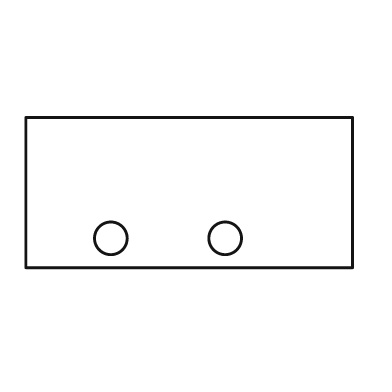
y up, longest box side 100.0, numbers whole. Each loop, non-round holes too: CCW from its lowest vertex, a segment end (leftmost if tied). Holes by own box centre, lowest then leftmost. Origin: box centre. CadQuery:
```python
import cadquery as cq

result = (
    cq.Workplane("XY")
    .moveTo(-50.0, -23.0)
    .lineTo(50.0, -23.0)
    .lineTo(50.0, 23.0)
    .lineTo(-50.0, 23.0)
    .close()
    .moveTo(-24.0, -14.0)
    .circle(5.0)
    .moveTo(11.0, -14.0)
    .circle(5.0)
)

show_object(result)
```